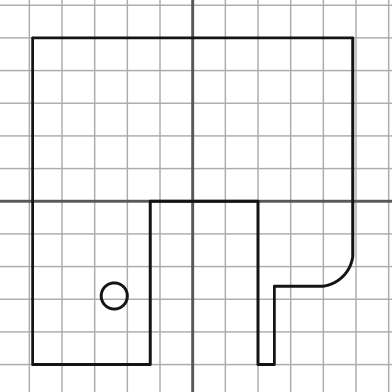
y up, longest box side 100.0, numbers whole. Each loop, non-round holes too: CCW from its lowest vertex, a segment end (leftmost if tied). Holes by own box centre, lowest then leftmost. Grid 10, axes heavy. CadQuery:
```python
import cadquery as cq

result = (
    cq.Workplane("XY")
    .moveTo(-49.0, -50.0)
    .lineTo(-13.0, -50.0)
    .lineTo(-13.0, 0.0)
    .lineTo(20.0, 0.0)
    .lineTo(20.0, -50.0)
    .lineTo(25.0, -50.0)
    .lineTo(25.0, -26.0)
    .lineTo(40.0, -26.0)
    .threePointArc((46.0, -23.0), (49.0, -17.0))
    .lineTo(49.0, 50.0)
    .lineTo(-49.0, 50.0)
    .close()
    .moveTo(-24.0, -29.0)
    .circle(4.0)
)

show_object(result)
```